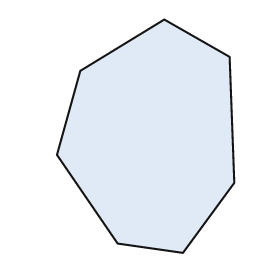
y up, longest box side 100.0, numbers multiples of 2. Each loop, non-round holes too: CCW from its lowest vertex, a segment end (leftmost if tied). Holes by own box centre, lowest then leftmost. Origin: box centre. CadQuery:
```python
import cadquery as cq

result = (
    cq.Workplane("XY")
    .moveTo(16.0, -50.0)
    .lineTo(38.0, -20.0)
    .lineTo(36.0, 34.0)
    .lineTo(8.0, 50.0)
    .lineTo(-28.0, 28.0)
    .lineTo(-38.0, -8.0)
    .lineTo(-12.0, -46.0)
    .close()
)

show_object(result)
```